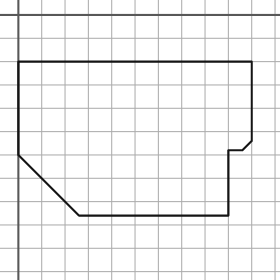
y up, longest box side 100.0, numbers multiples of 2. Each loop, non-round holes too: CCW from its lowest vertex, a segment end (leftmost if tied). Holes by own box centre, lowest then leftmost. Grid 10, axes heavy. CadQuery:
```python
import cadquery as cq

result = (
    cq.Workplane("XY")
    .moveTo(26.0, -86.0)
    .lineTo(90.0, -86.0)
    .lineTo(90.0, -58.0)
    .lineTo(96.0, -58.0)
    .lineTo(100.0, -54.0)
    .lineTo(100.0, -20.0)
    .lineTo(0.0, -20.0)
    .lineTo(0.0, -60.0)
    .close()
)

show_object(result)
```